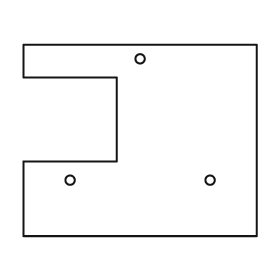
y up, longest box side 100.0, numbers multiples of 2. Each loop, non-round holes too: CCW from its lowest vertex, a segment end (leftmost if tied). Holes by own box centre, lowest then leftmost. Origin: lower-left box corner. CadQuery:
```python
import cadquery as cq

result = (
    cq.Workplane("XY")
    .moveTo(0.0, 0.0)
    .lineTo(100.0, 0.0)
    .lineTo(100.0, 82.0)
    .lineTo(0.0, 82.0)
    .lineTo(0.0, 68.0)
    .lineTo(40.0, 68.0)
    .lineTo(40.0, 32.0)
    .lineTo(0.0, 32.0)
    .close()
    .moveTo(20.0, 24.0)
    .circle(2.0)
    .moveTo(80.0, 24.0)
    .circle(2.0)
    .moveTo(50.0, 76.0)
    .circle(2.0)
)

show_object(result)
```